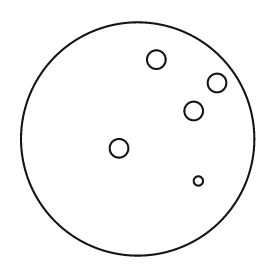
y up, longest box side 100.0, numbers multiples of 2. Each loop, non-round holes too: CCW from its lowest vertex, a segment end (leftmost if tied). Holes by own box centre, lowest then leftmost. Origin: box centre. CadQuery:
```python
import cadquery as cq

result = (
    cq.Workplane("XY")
    .moveTo(0.0, 0.0)
    .circle(50.0)
    .moveTo(26.0, -18.0)
    .circle(2.0)
    .moveTo(-8.0, -4.0)
    .circle(4.0)
    .moveTo(24.0, 12.0)
    .circle(4.0)
    .moveTo(34.0, 24.0)
    .circle(4.0)
    .moveTo(8.0, 34.0)
    .circle(4.0)
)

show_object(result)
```